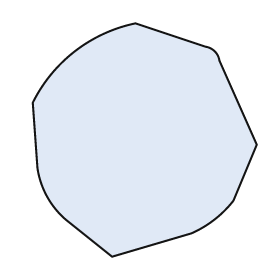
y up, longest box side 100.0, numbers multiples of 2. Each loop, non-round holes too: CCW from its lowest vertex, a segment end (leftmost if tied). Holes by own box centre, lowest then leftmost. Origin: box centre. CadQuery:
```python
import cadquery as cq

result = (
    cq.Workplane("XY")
    .moveTo(-14.0, -50.0)
    .lineTo(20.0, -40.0)
    .threePointArc((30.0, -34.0), (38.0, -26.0))
    .lineTo(48.0, -2.0)
    .lineTo(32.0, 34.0)
    .threePointArc((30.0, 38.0), (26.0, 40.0))
    .lineTo(-4.0, 50.0)
    .threePointArc((-30.0, 38.0), (-48.0, 16.0))
    .lineTo(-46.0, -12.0)
    .threePointArc((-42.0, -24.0), (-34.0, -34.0))
    .close()
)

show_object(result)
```